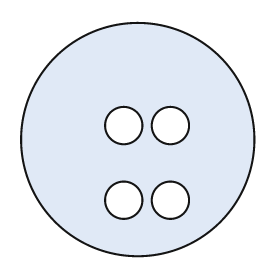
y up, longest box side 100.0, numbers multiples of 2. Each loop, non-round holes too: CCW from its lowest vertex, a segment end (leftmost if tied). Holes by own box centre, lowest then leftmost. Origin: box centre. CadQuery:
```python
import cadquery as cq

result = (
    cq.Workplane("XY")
    .moveTo(0.0, 0.0)
    .circle(50.0)
    .moveTo(-6.0, -26.0)
    .circle(8.0)
    .moveTo(14.0, -26.0)
    .circle(8.0)
    .moveTo(-6.0, 6.0)
    .circle(8.0)
    .moveTo(14.0, 6.0)
    .circle(8.0)
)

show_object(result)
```